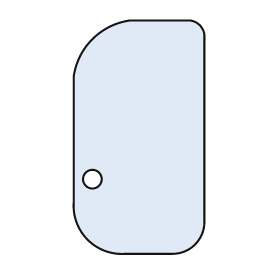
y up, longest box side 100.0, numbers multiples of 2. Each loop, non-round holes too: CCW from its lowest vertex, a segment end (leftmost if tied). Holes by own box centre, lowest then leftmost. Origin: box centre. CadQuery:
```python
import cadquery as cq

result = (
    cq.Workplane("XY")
    .moveTo(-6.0, -50.0)
    .lineTo(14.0, -50.0)
    .threePointArc((24.0, -46.0), (28.0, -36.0))
    .lineTo(28.0, 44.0)
    .threePointArc((26.0, 48.0), (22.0, 50.0))
    .lineTo(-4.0, 50.0)
    .threePointArc((-20.0, 42.0), (-28.0, 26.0))
    .lineTo(-28.0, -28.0)
    .threePointArc((-22.0, -44.0), (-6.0, -50.0))
    .close()
    .moveTo(-20.0, -18.0)
    .circle(4.0)
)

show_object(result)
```